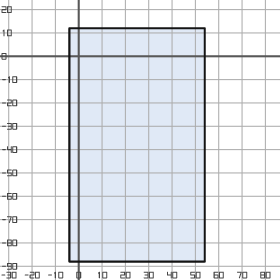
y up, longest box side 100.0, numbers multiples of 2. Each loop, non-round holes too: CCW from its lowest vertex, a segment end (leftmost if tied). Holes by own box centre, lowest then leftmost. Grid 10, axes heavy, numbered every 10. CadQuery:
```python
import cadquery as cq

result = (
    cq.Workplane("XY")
    .moveTo(-4.0, -88.0)
    .lineTo(54.0, -88.0)
    .lineTo(54.0, 12.0)
    .lineTo(-4.0, 12.0)
    .close()
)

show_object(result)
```